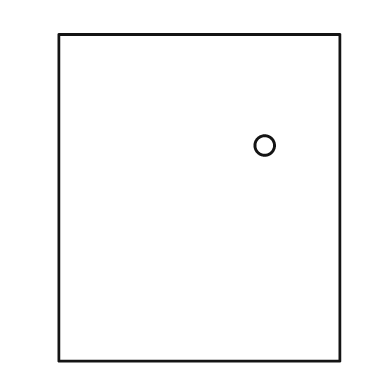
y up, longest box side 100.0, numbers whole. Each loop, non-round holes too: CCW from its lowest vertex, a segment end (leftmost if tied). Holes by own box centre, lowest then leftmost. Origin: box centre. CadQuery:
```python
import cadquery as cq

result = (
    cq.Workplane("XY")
    .moveTo(-43.0, -50.0)
    .lineTo(43.0, -50.0)
    .lineTo(43.0, 50.0)
    .lineTo(-43.0, 50.0)
    .close()
    .moveTo(20.0, 16.0)
    .circle(3.0)
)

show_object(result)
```